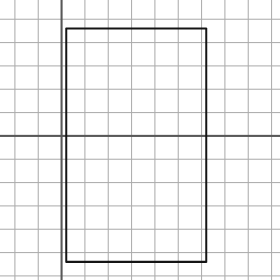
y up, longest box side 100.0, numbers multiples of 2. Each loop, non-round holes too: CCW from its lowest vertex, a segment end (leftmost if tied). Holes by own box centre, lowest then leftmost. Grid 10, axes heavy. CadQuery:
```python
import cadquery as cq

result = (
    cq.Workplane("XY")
    .moveTo(2.0, -54.0)
    .lineTo(62.0, -54.0)
    .lineTo(62.0, 46.0)
    .lineTo(2.0, 46.0)
    .close()
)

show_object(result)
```